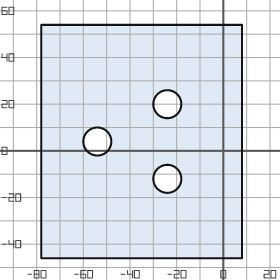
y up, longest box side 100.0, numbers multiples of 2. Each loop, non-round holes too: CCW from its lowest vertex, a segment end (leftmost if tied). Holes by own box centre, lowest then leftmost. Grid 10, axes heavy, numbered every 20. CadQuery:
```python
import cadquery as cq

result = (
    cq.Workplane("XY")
    .moveTo(-78.0, -46.0)
    .lineTo(8.0, -46.0)
    .lineTo(8.0, 54.0)
    .lineTo(-78.0, 54.0)
    .close()
    .moveTo(-24.0, -12.0)
    .circle(6.0)
    .moveTo(-54.0, 4.0)
    .circle(6.0)
    .moveTo(-24.0, 20.0)
    .circle(6.0)
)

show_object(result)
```